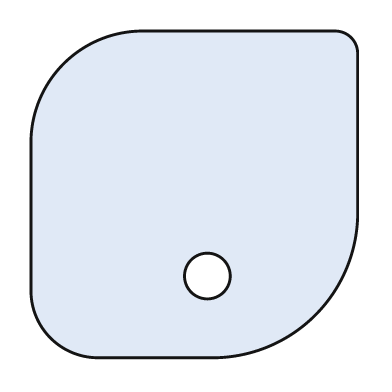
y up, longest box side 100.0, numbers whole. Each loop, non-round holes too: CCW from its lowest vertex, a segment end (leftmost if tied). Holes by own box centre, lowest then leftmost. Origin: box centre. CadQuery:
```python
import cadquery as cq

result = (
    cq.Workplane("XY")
    .moveTo(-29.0, -50.0)
    .lineTo(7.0, -50.0)
    .threePointArc((37.0, -37.0), (50.0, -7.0))
    .lineTo(50.0, 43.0)
    .threePointArc((48.0, 48.0), (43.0, 50.0))
    .lineTo(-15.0, 50.0)
    .threePointArc((-40.0, 40.0), (-50.0, 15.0))
    .lineTo(-50.0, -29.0)
    .threePointArc((-44.0, -44.0), (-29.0, -50.0))
    .close()
    .moveTo(4.0, -25.0)
    .circle(7.0)
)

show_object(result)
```